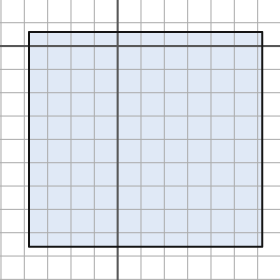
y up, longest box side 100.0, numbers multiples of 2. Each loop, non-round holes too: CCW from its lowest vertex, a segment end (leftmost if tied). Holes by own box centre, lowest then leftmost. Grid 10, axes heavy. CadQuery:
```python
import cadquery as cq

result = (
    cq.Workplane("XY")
    .moveTo(-38.0, -86.0)
    .lineTo(62.0, -86.0)
    .lineTo(62.0, 6.0)
    .lineTo(-38.0, 6.0)
    .close()
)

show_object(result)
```